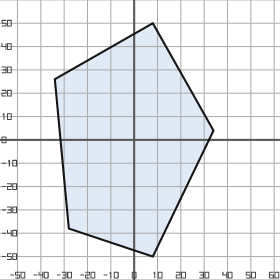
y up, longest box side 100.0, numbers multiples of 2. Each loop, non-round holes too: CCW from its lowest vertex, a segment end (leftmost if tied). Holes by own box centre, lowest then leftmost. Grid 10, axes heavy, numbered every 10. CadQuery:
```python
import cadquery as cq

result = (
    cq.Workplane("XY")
    .moveTo(8.0, -50.0)
    .lineTo(34.0, 4.0)
    .lineTo(8.0, 50.0)
    .lineTo(-34.0, 26.0)
    .lineTo(-28.0, -38.0)
    .close()
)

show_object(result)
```